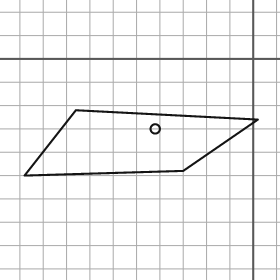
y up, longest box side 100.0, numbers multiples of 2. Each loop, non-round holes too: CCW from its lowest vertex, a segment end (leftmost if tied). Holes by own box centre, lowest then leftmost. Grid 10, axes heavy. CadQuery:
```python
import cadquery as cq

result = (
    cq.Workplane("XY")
    .moveTo(-98.0, -50.0)
    .lineTo(-30.0, -48.0)
    .lineTo(2.0, -26.0)
    .lineTo(-76.0, -22.0)
    .close()
    .moveTo(-42.0, -30.0)
    .circle(2.0)
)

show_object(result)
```